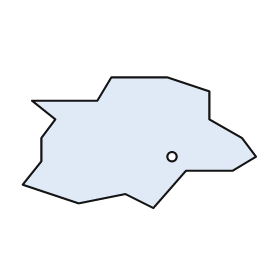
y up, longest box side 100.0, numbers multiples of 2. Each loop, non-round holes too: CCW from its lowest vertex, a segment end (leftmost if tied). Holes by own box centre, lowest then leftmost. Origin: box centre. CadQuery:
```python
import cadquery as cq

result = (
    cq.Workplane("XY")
    .moveTo(6.0, -28.0)
    .lineTo(20.0, -12.0)
    .lineTo(40.0, -12.0)
    .lineTo(50.0, -6.0)
    .lineTo(44.0, 2.0)
    .lineTo(30.0, 10.0)
    .lineTo(30.0, 22.0)
    .lineTo(12.0, 28.0)
    .lineTo(-12.0, 28.0)
    .lineTo(-18.0, 18.0)
    .lineTo(-46.0, 18.0)
    .lineTo(-36.0, 10.0)
    .lineTo(-42.0, 2.0)
    .lineTo(-42.0, -8.0)
    .lineTo(-50.0, -18.0)
    .lineTo(-26.0, -26.0)
    .lineTo(-6.0, -22.0)
    .close()
    .moveTo(14.0, -6.0)
    .circle(2.0)
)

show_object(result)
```